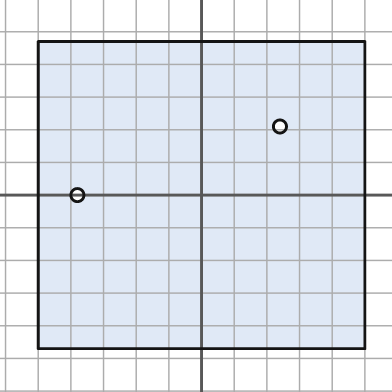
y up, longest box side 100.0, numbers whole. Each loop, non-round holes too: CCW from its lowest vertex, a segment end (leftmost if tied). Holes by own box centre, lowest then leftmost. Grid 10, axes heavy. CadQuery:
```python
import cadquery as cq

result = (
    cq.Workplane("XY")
    .moveTo(-50.0, -47.0)
    .lineTo(50.0, -47.0)
    .lineTo(50.0, 47.0)
    .lineTo(-50.0, 47.0)
    .close()
    .moveTo(-38.0, 0.0)
    .circle(2.0)
    .moveTo(24.0, 21.0)
    .circle(2.0)
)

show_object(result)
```